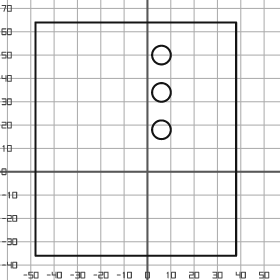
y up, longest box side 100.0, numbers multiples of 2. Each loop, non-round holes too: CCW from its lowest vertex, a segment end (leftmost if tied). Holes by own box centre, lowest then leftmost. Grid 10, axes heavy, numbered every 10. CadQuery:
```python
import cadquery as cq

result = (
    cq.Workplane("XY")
    .moveTo(-48.0, -36.0)
    .lineTo(38.0, -36.0)
    .lineTo(38.0, 64.0)
    .lineTo(-48.0, 64.0)
    .close()
    .moveTo(6.0, 18.0)
    .circle(4.0)
    .moveTo(6.0, 34.0)
    .circle(4.0)
    .moveTo(6.0, 50.0)
    .circle(4.0)
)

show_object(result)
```